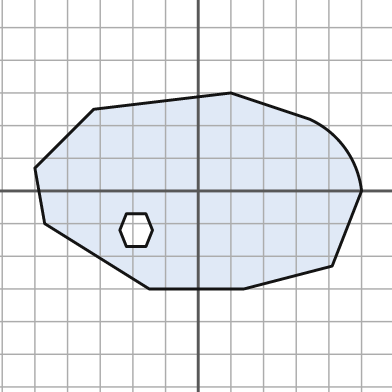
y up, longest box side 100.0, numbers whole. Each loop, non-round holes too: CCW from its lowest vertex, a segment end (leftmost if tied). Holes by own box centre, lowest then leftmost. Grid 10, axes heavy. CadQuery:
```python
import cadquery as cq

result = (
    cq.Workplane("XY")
    .moveTo(-15.0, -30.0)
    .lineTo(14.0, -30.0)
    .lineTo(41.0, -23.0)
    .lineTo(50.0, 0.0)
    .threePointArc((45.0, 13.0), (34.0, 22.0))
    .lineTo(10.0, 30.0)
    .lineTo(-32.0, 25.0)
    .lineTo(-50.0, 7.0)
    .lineTo(-47.0, -10.0)
    .close()
    .moveTo(-22.0, -17.0)
    .lineTo(-16.0, -17.0)
    .lineTo(-14.0, -12.0)
    .lineTo(-16.0, -7.0)
    .lineTo(-22.0, -7.0)
    .lineTo(-24.0, -12.0)
    .close()
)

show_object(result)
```